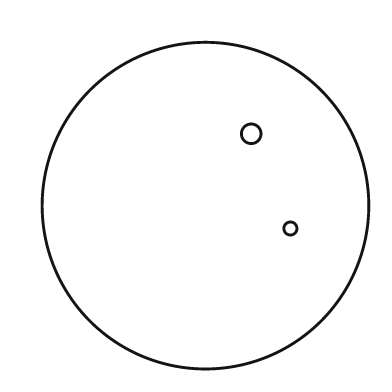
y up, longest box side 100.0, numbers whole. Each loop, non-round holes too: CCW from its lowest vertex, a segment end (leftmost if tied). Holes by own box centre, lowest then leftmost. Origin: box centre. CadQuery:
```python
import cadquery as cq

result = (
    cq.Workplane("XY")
    .moveTo(0.0, 0.0)
    .circle(50.0)
    .moveTo(26.0, -7.0)
    .circle(2.0)
    .moveTo(14.0, 22.0)
    .circle(3.0)
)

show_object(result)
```